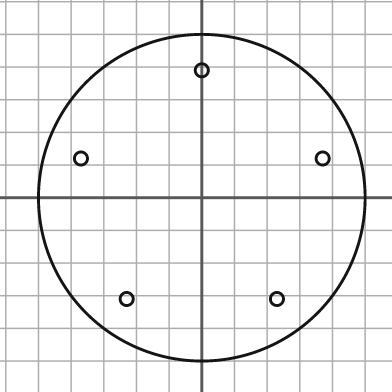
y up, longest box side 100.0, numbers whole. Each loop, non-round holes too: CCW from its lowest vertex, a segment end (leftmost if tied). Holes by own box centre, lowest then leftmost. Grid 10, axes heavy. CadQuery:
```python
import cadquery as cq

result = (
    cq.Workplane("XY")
    .moveTo(0.0, 0.0)
    .circle(50.0)
    .moveTo(-23.0, -31.0)
    .circle(2.0)
    .moveTo(23.0, -31.0)
    .circle(2.0)
    .moveTo(-37.0, 12.0)
    .circle(2.0)
    .moveTo(37.0, 12.0)
    .circle(2.0)
    .moveTo(0.0, 39.0)
    .circle(2.0)
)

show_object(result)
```